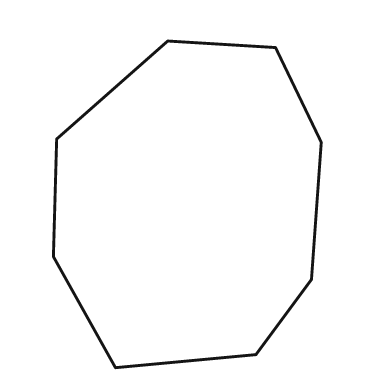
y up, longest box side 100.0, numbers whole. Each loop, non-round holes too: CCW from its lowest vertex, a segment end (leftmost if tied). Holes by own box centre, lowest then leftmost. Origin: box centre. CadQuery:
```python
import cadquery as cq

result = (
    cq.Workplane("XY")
    .moveTo(-22.0, -50.0)
    .lineTo(21.0, -46.0)
    .lineTo(38.0, -23.0)
    .lineTo(41.0, 19.0)
    .lineTo(27.0, 48.0)
    .lineTo(-6.0, 50.0)
    .lineTo(-40.0, 20.0)
    .lineTo(-41.0, -16.0)
    .close()
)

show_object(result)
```